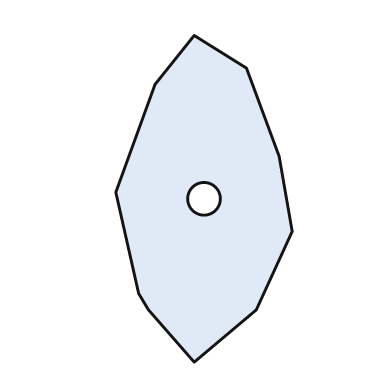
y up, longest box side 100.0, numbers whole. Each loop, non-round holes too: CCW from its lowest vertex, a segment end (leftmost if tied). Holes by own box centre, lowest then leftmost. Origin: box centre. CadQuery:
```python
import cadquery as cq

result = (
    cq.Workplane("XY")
    .moveTo(-3.0, -50.0)
    .lineTo(16.0, -34.0)
    .lineTo(27.0, -10.0)
    .lineTo(23.0, 13.0)
    .lineTo(13.0, 40.0)
    .lineTo(-3.0, 50.0)
    .lineTo(-15.0, 35.0)
    .lineTo(-27.0, 2.0)
    .lineTo(-20.0, -29.0)
    .lineTo(-17.0, -34.0)
    .close()
    .moveTo(0.0, 0.0)
    .circle(5.0)
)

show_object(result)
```